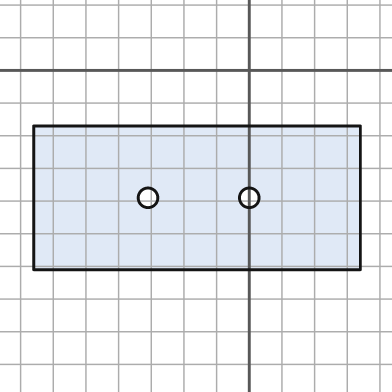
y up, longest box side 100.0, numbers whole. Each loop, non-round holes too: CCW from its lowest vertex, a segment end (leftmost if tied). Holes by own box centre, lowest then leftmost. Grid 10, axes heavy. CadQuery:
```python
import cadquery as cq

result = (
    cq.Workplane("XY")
    .moveTo(-66.0, -61.0)
    .lineTo(34.0, -61.0)
    .lineTo(34.0, -17.0)
    .lineTo(-66.0, -17.0)
    .close()
    .moveTo(-31.0, -39.0)
    .circle(3.0)
    .moveTo(0.0, -39.0)
    .circle(3.0)
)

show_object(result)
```